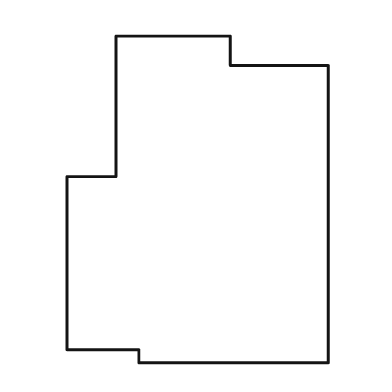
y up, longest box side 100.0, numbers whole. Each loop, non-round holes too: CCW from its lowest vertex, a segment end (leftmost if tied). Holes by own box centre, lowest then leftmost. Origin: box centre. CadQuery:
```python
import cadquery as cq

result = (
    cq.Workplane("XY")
    .moveTo(-18.0, -50.0)
    .lineTo(40.0, -50.0)
    .lineTo(40.0, 41.0)
    .lineTo(10.0, 41.0)
    .lineTo(10.0, 50.0)
    .lineTo(-25.0, 50.0)
    .lineTo(-25.0, 7.0)
    .lineTo(-40.0, 7.0)
    .lineTo(-40.0, -46.0)
    .lineTo(-18.0, -46.0)
    .close()
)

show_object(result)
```